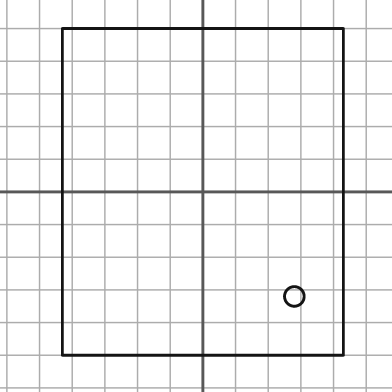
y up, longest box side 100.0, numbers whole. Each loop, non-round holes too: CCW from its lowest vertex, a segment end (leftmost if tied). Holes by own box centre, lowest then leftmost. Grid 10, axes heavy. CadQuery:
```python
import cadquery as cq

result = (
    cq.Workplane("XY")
    .moveTo(-43.0, -50.0)
    .lineTo(43.0, -50.0)
    .lineTo(43.0, 50.0)
    .lineTo(-43.0, 50.0)
    .close()
    .moveTo(28.0, -32.0)
    .circle(3.0)
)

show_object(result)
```